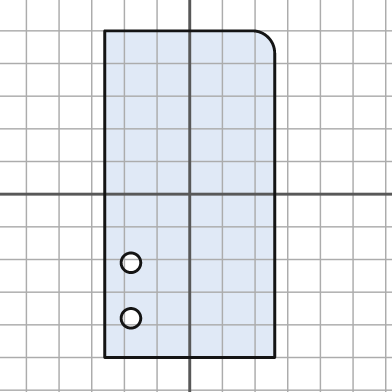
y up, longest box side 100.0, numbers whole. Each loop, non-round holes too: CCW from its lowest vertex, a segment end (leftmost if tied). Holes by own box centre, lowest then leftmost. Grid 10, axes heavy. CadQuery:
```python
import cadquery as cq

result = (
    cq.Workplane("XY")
    .moveTo(-26.0, -50.0)
    .lineTo(26.0, -50.0)
    .lineTo(26.0, 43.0)
    .threePointArc((24.0, 48.0), (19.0, 50.0))
    .lineTo(-26.0, 50.0)
    .close()
    .moveTo(-18.0, -38.0)
    .circle(3.0)
    .moveTo(-18.0, -21.0)
    .circle(3.0)
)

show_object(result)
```